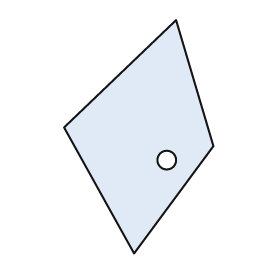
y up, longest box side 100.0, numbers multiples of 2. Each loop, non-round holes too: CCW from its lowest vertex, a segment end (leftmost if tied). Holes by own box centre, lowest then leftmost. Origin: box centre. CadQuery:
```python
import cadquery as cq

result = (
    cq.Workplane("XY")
    .moveTo(-2.0, -50.0)
    .lineTo(32.0, -4.0)
    .lineTo(16.0, 50.0)
    .lineTo(-32.0, 4.0)
    .close()
    .moveTo(12.0, -10.0)
    .circle(4.0)
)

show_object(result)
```